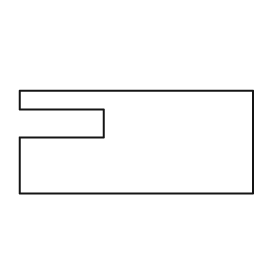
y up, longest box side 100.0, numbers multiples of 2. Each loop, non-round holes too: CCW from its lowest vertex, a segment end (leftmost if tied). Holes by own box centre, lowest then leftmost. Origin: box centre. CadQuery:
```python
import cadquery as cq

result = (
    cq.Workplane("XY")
    .moveTo(-50.0, -22.0)
    .lineTo(50.0, -22.0)
    .lineTo(50.0, 22.0)
    .lineTo(-50.0, 22.0)
    .lineTo(-50.0, 14.0)
    .lineTo(-14.0, 14.0)
    .lineTo(-14.0, 2.0)
    .lineTo(-50.0, 2.0)
    .close()
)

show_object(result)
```